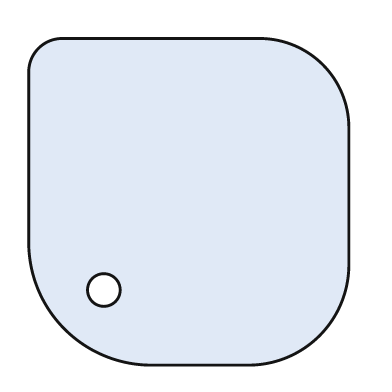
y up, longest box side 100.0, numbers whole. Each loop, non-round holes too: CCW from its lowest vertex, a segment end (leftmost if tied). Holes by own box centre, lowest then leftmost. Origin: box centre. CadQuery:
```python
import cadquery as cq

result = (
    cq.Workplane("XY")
    .moveTo(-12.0, -50.0)
    .lineTo(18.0, -50.0)
    .threePointArc((40.0, -41.0), (49.0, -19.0))
    .lineTo(49.0, 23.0)
    .threePointArc((41.0, 42.0), (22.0, 50.0))
    .lineTo(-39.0, 50.0)
    .threePointArc((-46.0, 47.0), (-49.0, 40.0))
    .lineTo(-49.0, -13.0)
    .threePointArc((-38.0, -39.0), (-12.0, -50.0))
    .close()
    .moveTo(-26.0, -27.0)
    .circle(5.0)
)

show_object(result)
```